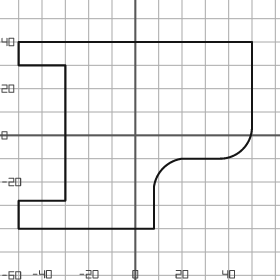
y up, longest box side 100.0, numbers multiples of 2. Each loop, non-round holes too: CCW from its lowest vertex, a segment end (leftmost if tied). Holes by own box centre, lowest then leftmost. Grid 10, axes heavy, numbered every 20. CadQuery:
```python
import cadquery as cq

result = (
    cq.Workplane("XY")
    .moveTo(-50.0, -40.0)
    .lineTo(8.0, -40.0)
    .lineTo(8.0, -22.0)
    .threePointArc((12.0, -14.0), (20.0, -10.0))
    .lineTo(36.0, -10.0)
    .threePointArc((46.0, -6.0), (50.0, 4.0))
    .lineTo(50.0, 40.0)
    .lineTo(-50.0, 40.0)
    .lineTo(-50.0, 30.0)
    .lineTo(-30.0, 30.0)
    .lineTo(-30.0, -28.0)
    .lineTo(-50.0, -28.0)
    .close()
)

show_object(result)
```